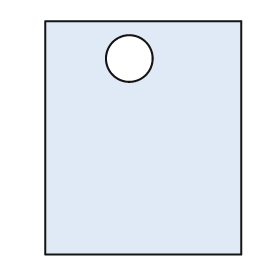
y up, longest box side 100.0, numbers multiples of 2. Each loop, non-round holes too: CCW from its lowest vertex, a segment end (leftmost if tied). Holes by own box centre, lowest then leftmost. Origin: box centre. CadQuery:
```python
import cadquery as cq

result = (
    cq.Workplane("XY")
    .moveTo(-42.0, -50.0)
    .lineTo(42.0, -50.0)
    .lineTo(42.0, 50.0)
    .lineTo(-42.0, 50.0)
    .close()
    .moveTo(-6.0, 34.0)
    .circle(10.0)
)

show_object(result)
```